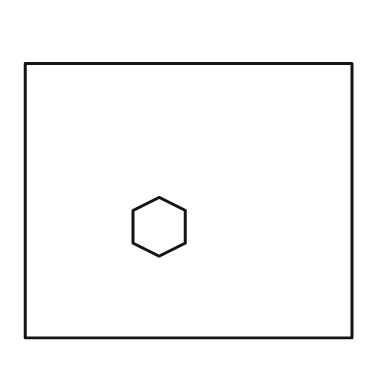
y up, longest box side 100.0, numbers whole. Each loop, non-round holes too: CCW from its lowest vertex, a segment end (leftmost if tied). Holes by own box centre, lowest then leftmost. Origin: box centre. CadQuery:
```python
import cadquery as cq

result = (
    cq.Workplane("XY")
    .moveTo(-50.0, -42.0)
    .lineTo(50.0, -42.0)
    .lineTo(50.0, 42.0)
    .lineTo(-50.0, 42.0)
    .close()
    .moveTo(-9.0, -17.0)
    .lineTo(-1.0, -13.0)
    .lineTo(-1.0, -3.0)
    .lineTo(-9.0, 1.0)
    .lineTo(-17.0, -3.0)
    .lineTo(-17.0, -13.0)
    .close()
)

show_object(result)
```